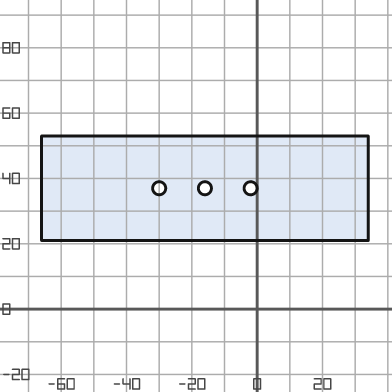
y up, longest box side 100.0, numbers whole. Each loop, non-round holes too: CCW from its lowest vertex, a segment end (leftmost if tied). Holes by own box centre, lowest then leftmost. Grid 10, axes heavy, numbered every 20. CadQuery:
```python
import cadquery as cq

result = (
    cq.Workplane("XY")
    .moveTo(-66.0, 21.0)
    .lineTo(34.0, 21.0)
    .lineTo(34.0, 53.0)
    .lineTo(-66.0, 53.0)
    .close()
    .moveTo(-30.0, 37.0)
    .circle(2.0)
    .moveTo(-16.0, 37.0)
    .circle(2.0)
    .moveTo(-2.0, 37.0)
    .circle(2.0)
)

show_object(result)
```